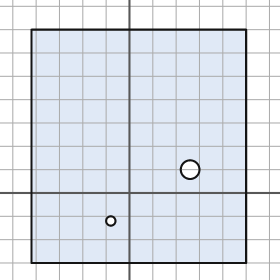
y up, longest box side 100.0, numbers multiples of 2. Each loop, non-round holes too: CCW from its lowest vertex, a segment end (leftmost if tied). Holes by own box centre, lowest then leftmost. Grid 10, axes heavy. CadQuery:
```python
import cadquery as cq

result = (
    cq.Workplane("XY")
    .moveTo(-42.0, -30.0)
    .lineTo(50.0, -30.0)
    .lineTo(50.0, 70.0)
    .lineTo(-42.0, 70.0)
    .close()
    .moveTo(-8.0, -12.0)
    .circle(2.0)
    .moveTo(26.0, 10.0)
    .circle(4.0)
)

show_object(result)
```